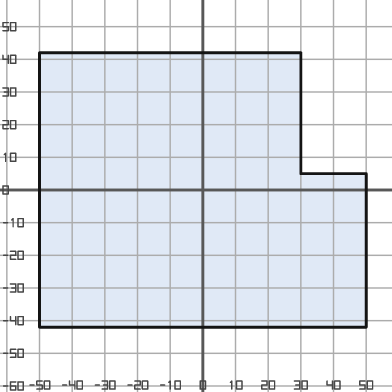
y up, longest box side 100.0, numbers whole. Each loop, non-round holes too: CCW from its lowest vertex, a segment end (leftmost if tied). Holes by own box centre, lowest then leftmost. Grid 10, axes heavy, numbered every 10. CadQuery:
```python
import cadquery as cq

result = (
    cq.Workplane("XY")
    .moveTo(-50.0, -42.0)
    .lineTo(50.0, -42.0)
    .lineTo(50.0, 5.0)
    .lineTo(30.0, 5.0)
    .lineTo(30.0, 42.0)
    .lineTo(-50.0, 42.0)
    .close()
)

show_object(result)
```